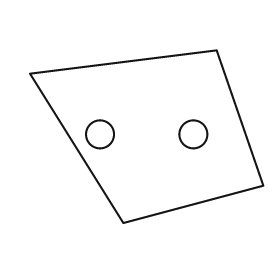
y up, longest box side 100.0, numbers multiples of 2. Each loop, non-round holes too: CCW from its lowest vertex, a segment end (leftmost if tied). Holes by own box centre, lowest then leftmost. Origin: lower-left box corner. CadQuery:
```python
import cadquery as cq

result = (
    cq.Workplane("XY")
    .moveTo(40.0, 0.0)
    .lineTo(100.0, 16.0)
    .lineTo(80.0, 74.0)
    .lineTo(0.0, 64.0)
    .close()
    .moveTo(30.0, 38.0)
    .circle(6.0)
    .moveTo(70.0, 38.0)
    .circle(6.0)
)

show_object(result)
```